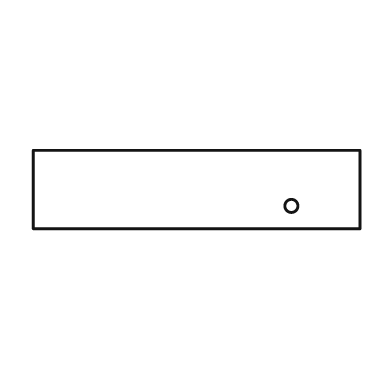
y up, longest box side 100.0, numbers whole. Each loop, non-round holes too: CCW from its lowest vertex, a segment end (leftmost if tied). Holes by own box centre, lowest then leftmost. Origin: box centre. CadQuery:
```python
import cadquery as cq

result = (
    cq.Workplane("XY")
    .moveTo(-50.0, -12.0)
    .lineTo(50.0, -12.0)
    .lineTo(50.0, 12.0)
    .lineTo(-50.0, 12.0)
    .close()
    .moveTo(29.0, -5.0)
    .circle(2.0)
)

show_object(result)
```